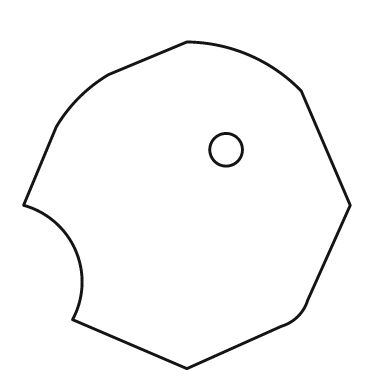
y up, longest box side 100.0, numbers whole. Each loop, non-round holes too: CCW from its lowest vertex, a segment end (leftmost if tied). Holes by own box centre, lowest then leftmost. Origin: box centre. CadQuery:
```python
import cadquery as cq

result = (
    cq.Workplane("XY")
    .moveTo(0.0, -50.0)
    .lineTo(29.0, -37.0)
    .threePointArc((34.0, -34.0), (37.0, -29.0))
    .lineTo(50.0, 0.0)
    .lineTo(35.0, 35.0)
    .threePointArc((19.0, 46.0), (0.0, 50.0))
    .lineTo(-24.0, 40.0)
    .threePointArc((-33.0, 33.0), (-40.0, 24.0))
    .lineTo(-50.0, 0.0)
    .threePointArc((-34.0, -14.0), (-35.0, -35.0))
    .close()
    .moveTo(12.0, 17.0)
    .circle(5.0)
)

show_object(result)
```